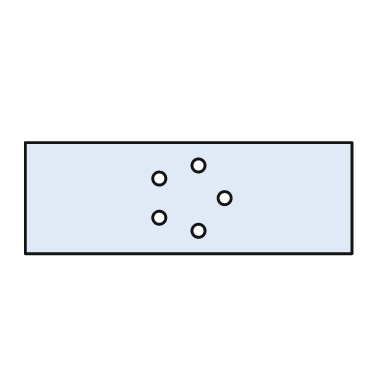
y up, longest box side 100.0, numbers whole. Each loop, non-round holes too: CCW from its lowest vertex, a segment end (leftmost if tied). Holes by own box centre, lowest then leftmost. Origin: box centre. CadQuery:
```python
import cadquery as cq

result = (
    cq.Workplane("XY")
    .moveTo(-50.0, -17.0)
    .lineTo(50.0, -17.0)
    .lineTo(50.0, 17.0)
    .lineTo(-50.0, 17.0)
    .close()
    .moveTo(3.0, -10.0)
    .circle(2.0)
    .moveTo(-9.0, -6.0)
    .circle(2.0)
    .moveTo(11.0, 0.0)
    .circle(2.0)
    .moveTo(-9.0, 6.0)
    .circle(2.0)
    .moveTo(3.0, 10.0)
    .circle(2.0)
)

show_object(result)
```